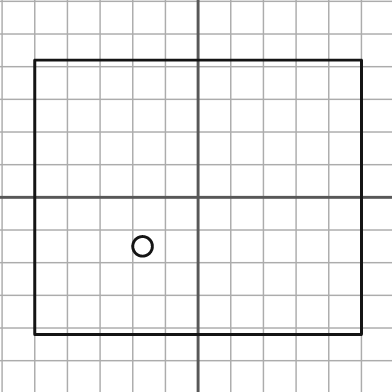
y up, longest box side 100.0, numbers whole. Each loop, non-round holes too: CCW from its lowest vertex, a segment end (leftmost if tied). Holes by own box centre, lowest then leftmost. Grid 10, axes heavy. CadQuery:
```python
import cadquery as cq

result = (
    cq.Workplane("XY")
    .moveTo(-50.0, -42.0)
    .lineTo(50.0, -42.0)
    .lineTo(50.0, 42.0)
    .lineTo(-50.0, 42.0)
    .close()
    .moveTo(-17.0, -15.0)
    .circle(3.0)
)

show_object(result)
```